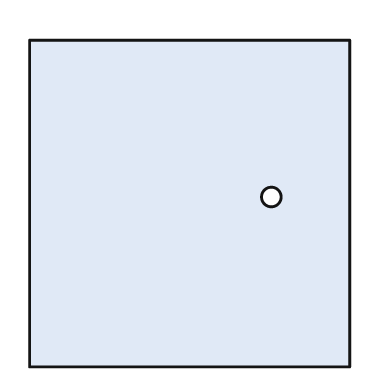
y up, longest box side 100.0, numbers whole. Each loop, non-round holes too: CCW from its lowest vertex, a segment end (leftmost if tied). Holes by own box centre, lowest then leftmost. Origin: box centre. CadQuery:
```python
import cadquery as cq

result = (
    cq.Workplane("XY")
    .moveTo(-49.0, -50.0)
    .lineTo(49.0, -50.0)
    .lineTo(49.0, 50.0)
    .lineTo(-49.0, 50.0)
    .close()
    .moveTo(25.0, 2.0)
    .circle(3.0)
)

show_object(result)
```